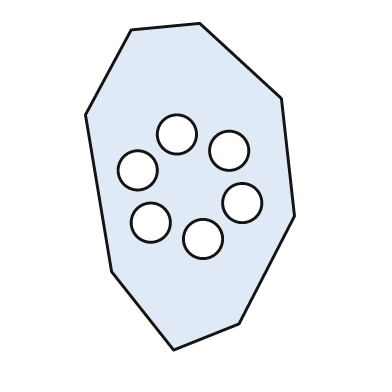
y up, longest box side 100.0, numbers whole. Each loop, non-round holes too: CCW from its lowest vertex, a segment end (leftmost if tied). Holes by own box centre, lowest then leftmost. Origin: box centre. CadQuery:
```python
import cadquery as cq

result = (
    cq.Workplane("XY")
    .moveTo(-5.0, -50.0)
    .lineTo(15.0, -42.0)
    .lineTo(32.0, -9.0)
    .lineTo(28.0, 27.0)
    .lineTo(3.0, 50.0)
    .lineTo(-18.0, 48.0)
    .lineTo(-32.0, 22.0)
    .lineTo(-24.0, -26.0)
    .close()
    .moveTo(4.0, -16.0)
    .circle(6.0)
    .moveTo(-12.0, -11.0)
    .circle(6.0)
    .moveTo(16.0, -5.0)
    .circle(6.0)
    .moveTo(-16.0, 5.0)
    .circle(6.0)
    .moveTo(12.0, 11.0)
    .circle(6.0)
    .moveTo(-4.0, 16.0)
    .circle(6.0)
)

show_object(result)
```